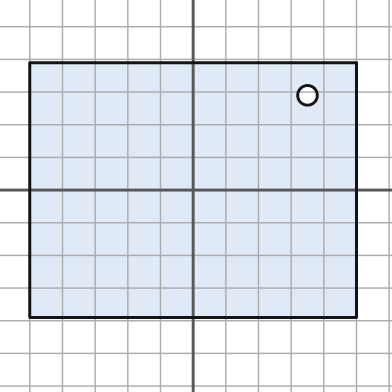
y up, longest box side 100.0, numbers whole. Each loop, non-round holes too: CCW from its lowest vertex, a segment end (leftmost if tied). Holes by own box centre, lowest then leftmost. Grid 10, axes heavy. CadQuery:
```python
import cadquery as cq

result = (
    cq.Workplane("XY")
    .moveTo(-50.0, -39.0)
    .lineTo(50.0, -39.0)
    .lineTo(50.0, 39.0)
    .lineTo(-50.0, 39.0)
    .close()
    .moveTo(35.0, 29.0)
    .circle(3.0)
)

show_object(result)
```